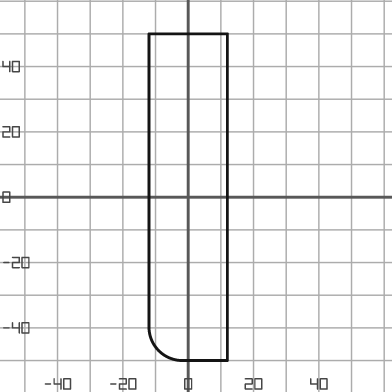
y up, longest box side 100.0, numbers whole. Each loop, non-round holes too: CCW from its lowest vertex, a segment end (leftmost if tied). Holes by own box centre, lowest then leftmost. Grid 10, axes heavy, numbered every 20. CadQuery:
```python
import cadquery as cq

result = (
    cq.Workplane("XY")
    .moveTo(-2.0, -50.0)
    .lineTo(12.0, -50.0)
    .lineTo(12.0, 50.0)
    .lineTo(-12.0, 50.0)
    .lineTo(-12.0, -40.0)
    .threePointArc((-9.0, -47.0), (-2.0, -50.0))
    .close()
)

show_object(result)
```